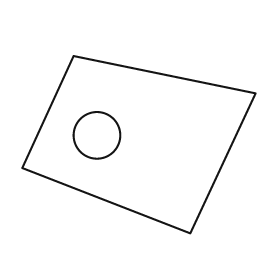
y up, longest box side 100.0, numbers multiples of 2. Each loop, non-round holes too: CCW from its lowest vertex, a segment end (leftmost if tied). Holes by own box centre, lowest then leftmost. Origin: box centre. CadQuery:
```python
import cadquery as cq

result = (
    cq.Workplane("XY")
    .moveTo(22.0, -38.0)
    .lineTo(50.0, 22.0)
    .lineTo(-28.0, 38.0)
    .lineTo(-50.0, -10.0)
    .close()
    .moveTo(-18.0, 4.0)
    .circle(10.0)
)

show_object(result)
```